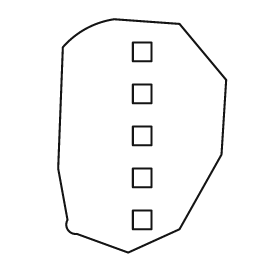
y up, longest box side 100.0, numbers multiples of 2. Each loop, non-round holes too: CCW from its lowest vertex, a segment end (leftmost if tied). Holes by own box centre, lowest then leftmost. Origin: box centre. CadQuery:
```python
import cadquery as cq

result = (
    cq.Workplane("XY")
    .moveTo(-6.0, -50.0)
    .lineTo(16.0, -40.0)
    .lineTo(34.0, -8.0)
    .lineTo(36.0, 24.0)
    .lineTo(16.0, 48.0)
    .lineTo(-12.0, 50.0)
    .threePointArc((-24.0, 46.0), (-34.0, 38.0))
    .lineTo(-36.0, -14.0)
    .lineTo(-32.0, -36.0)
    .threePointArc((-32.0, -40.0), (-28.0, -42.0))
    .close()
    .moveTo(-4.0, -40.0)
    .lineTo(4.0, -40.0)
    .lineTo(4.0, -32.0)
    .lineTo(-4.0, -32.0)
    .close()
    .moveTo(-4.0, -22.0)
    .lineTo(4.0, -22.0)
    .lineTo(4.0, -14.0)
    .lineTo(-4.0, -14.0)
    .close()
    .moveTo(-4.0, -4.0)
    .lineTo(4.0, -4.0)
    .lineTo(4.0, 4.0)
    .lineTo(-4.0, 4.0)
    .close()
    .moveTo(-4.0, 14.0)
    .lineTo(4.0, 14.0)
    .lineTo(4.0, 22.0)
    .lineTo(-4.0, 22.0)
    .close()
    .moveTo(-4.0, 32.0)
    .lineTo(4.0, 32.0)
    .lineTo(4.0, 40.0)
    .lineTo(-4.0, 40.0)
    .close()
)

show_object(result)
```